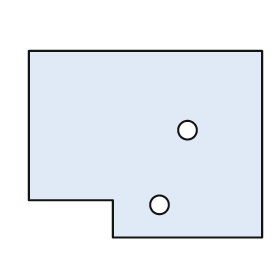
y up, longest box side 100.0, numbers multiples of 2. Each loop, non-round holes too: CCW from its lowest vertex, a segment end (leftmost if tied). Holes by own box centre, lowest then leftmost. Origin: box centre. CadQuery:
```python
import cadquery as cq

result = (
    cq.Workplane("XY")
    .moveTo(-14.0, -40.0)
    .lineTo(50.0, -40.0)
    .lineTo(50.0, 40.0)
    .lineTo(-50.0, 40.0)
    .lineTo(-50.0, -24.0)
    .lineTo(-14.0, -24.0)
    .close()
    .moveTo(6.0, -26.0)
    .circle(4.0)
    .moveTo(18.0, 6.0)
    .circle(4.0)
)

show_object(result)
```